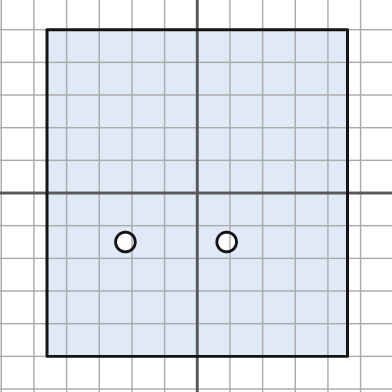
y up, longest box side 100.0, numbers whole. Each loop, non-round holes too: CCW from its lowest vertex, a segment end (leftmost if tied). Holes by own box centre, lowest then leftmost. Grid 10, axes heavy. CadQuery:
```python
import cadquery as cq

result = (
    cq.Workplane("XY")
    .moveTo(-46.0, -50.0)
    .lineTo(46.0, -50.0)
    .lineTo(46.0, 50.0)
    .lineTo(-46.0, 50.0)
    .close()
    .moveTo(-22.0, -15.0)
    .circle(3.0)
    .moveTo(9.0, -15.0)
    .circle(3.0)
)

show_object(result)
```